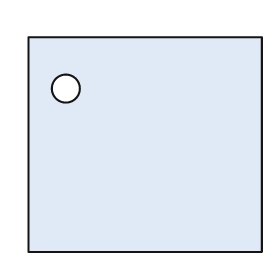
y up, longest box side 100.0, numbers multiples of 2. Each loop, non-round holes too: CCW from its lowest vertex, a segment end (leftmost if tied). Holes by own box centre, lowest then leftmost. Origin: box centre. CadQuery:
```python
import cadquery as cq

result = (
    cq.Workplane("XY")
    .moveTo(-50.0, -46.0)
    .lineTo(50.0, -46.0)
    .lineTo(50.0, 46.0)
    .lineTo(-50.0, 46.0)
    .close()
    .moveTo(-34.0, 24.0)
    .circle(6.0)
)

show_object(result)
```